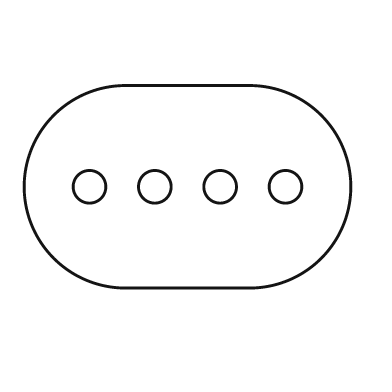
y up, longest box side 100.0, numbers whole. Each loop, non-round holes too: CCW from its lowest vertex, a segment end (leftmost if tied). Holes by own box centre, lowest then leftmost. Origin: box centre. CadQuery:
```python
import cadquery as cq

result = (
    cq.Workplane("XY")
    .moveTo(-19.0, -31.0)
    .lineTo(19.0, -31.0)
    .threePointArc((50.0, 0.0), (19.0, 31.0))
    .lineTo(-19.0, 31.0)
    .threePointArc((-50.0, 0.0), (-19.0, -31.0))
    .close()
    .moveTo(-30.0, 0.0)
    .circle(5.0)
    .moveTo(-10.0, 0.0)
    .circle(5.0)
    .moveTo(10.0, 0.0)
    .circle(5.0)
    .moveTo(30.0, 0.0)
    .circle(5.0)
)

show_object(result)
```